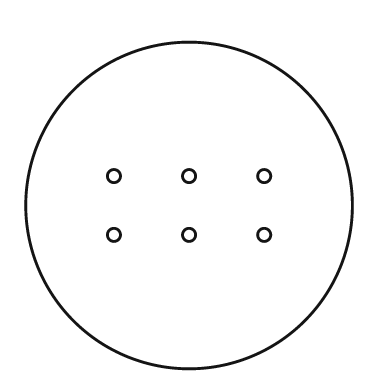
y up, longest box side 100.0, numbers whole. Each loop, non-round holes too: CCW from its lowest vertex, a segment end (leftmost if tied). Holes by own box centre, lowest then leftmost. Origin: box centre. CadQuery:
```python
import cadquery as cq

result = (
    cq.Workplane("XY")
    .moveTo(0.0, 0.0)
    .circle(50.0)
    .moveTo(-23.0, -9.0)
    .circle(2.0)
    .moveTo(0.0, -9.0)
    .circle(2.0)
    .moveTo(23.0, -9.0)
    .circle(2.0)
    .moveTo(-23.0, 9.0)
    .circle(2.0)
    .moveTo(0.0, 9.0)
    .circle(2.0)
    .moveTo(23.0, 9.0)
    .circle(2.0)
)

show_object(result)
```